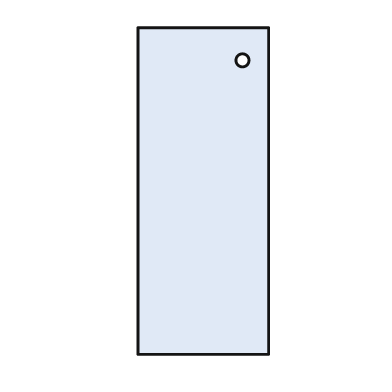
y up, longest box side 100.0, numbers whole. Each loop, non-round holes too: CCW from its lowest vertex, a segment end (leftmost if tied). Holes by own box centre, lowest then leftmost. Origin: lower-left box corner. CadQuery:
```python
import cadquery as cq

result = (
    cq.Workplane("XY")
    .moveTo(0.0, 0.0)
    .lineTo(40.0, 0.0)
    .lineTo(40.0, 100.0)
    .lineTo(0.0, 100.0)
    .close()
    .moveTo(32.0, 90.0)
    .circle(2.0)
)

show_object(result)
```